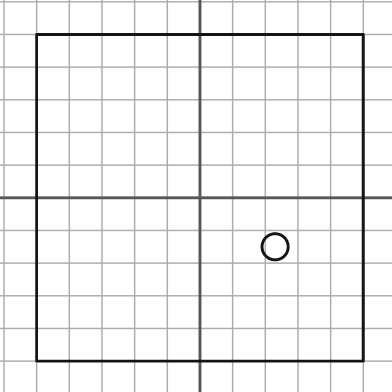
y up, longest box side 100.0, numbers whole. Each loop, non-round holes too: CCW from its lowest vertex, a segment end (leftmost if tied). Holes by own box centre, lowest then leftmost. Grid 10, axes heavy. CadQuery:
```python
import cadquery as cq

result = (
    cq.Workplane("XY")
    .moveTo(-50.0, -50.0)
    .lineTo(50.0, -50.0)
    .lineTo(50.0, 50.0)
    .lineTo(-50.0, 50.0)
    .close()
    .moveTo(23.0, -15.0)
    .circle(4.0)
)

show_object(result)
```